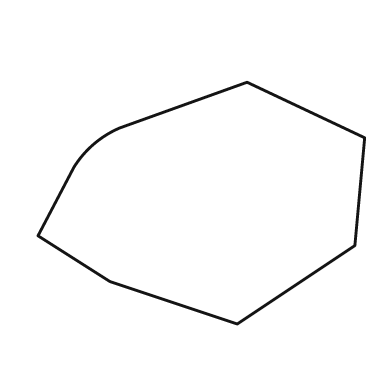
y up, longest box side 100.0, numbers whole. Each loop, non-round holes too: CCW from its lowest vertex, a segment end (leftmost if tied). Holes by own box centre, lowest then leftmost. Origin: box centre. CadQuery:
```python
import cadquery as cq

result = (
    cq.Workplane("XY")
    .moveTo(11.0, -37.0)
    .lineTo(47.0, -13.0)
    .lineTo(50.0, 20.0)
    .lineTo(14.0, 37.0)
    .lineTo(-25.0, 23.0)
    .threePointArc((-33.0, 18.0), (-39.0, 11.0))
    .lineTo(-50.0, -10.0)
    .lineTo(-28.0, -24.0)
    .close()
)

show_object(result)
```